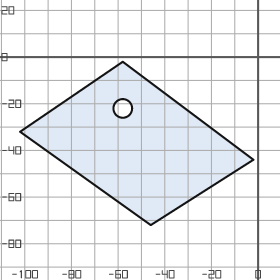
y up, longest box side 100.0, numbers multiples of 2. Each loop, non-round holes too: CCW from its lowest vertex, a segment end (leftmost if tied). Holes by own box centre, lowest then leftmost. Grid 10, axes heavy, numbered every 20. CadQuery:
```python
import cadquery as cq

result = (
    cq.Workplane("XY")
    .moveTo(-46.0, -72.0)
    .lineTo(-2.0, -44.0)
    .lineTo(-58.0, -2.0)
    .lineTo(-102.0, -32.0)
    .close()
    .moveTo(-58.0, -22.0)
    .circle(4.0)
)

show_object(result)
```